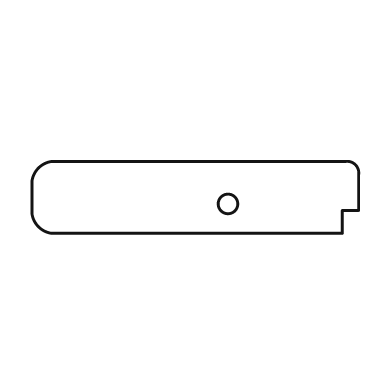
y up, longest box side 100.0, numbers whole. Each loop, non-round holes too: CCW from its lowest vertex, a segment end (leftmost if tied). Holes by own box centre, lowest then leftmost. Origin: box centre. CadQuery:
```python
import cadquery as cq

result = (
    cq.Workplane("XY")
    .moveTo(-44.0, -11.0)
    .lineTo(45.0, -11.0)
    .lineTo(45.0, -4.0)
    .lineTo(50.0, -4.0)
    .lineTo(50.0, 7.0)
    .threePointArc((49.0, 10.0), (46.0, 11.0))
    .lineTo(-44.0, 11.0)
    .threePointArc((-48.0, 9.0), (-50.0, 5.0))
    .lineTo(-50.0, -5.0)
    .threePointArc((-48.0, -9.0), (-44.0, -11.0))
    .close()
    .moveTo(10.0, -2.0)
    .circle(3.0)
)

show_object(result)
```